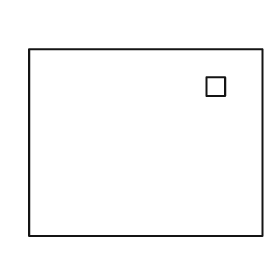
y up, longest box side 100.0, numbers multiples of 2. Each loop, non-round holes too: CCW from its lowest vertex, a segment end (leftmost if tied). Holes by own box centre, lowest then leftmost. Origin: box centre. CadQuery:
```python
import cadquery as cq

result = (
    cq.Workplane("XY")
    .moveTo(-50.0, -40.0)
    .lineTo(50.0, -40.0)
    .lineTo(50.0, 40.0)
    .lineTo(-50.0, 40.0)
    .close()
    .moveTo(26.0, 20.0)
    .lineTo(34.0, 20.0)
    .lineTo(34.0, 28.0)
    .lineTo(26.0, 28.0)
    .close()
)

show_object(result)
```